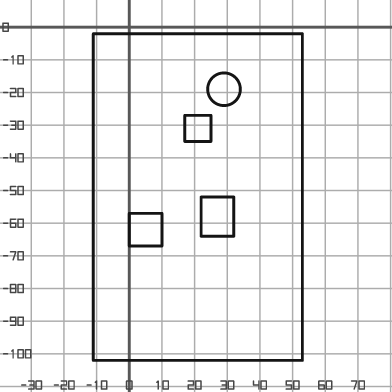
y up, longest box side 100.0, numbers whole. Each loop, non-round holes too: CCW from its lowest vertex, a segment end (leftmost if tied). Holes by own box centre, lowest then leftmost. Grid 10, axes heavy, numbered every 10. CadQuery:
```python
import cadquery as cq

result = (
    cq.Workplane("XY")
    .moveTo(-11.0, -102.0)
    .lineTo(53.0, -102.0)
    .lineTo(53.0, -2.0)
    .lineTo(-11.0, -2.0)
    .close()
    .moveTo(0.0, -67.0)
    .lineTo(10.0, -67.0)
    .lineTo(10.0, -57.0)
    .lineTo(0.0, -57.0)
    .close()
    .moveTo(22.0, -64.0)
    .lineTo(32.0, -64.0)
    .lineTo(32.0, -52.0)
    .lineTo(22.0, -52.0)
    .close()
    .moveTo(17.0, -35.0)
    .lineTo(25.0, -35.0)
    .lineTo(25.0, -27.0)
    .lineTo(17.0, -27.0)
    .close()
    .moveTo(29.0, -19.0)
    .circle(5.0)
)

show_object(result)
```